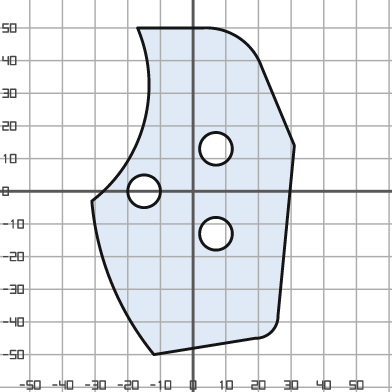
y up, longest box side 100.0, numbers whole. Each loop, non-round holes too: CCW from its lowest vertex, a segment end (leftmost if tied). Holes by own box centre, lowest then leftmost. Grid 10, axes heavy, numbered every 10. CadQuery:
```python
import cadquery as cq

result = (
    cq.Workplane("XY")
    .moveTo(-12.0, -50.0)
    .lineTo(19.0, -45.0)
    .threePointArc((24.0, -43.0), (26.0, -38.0))
    .lineTo(31.0, 14.0)
    .lineTo(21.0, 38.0)
    .threePointArc((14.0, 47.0), (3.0, 50.0))
    .lineTo(-17.0, 50.0)
    .threePointArc((-15.0, 21.0), (-31.0, -3.0))
    .threePointArc((-25.0, -28.0), (-12.0, -50.0))
    .close()
    .moveTo(7.0, -13.0)
    .circle(5.0)
    .moveTo(-15.0, 0.0)
    .circle(5.0)
    .moveTo(7.0, 13.0)
    .circle(5.0)
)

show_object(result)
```